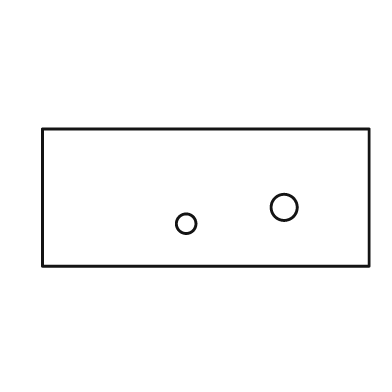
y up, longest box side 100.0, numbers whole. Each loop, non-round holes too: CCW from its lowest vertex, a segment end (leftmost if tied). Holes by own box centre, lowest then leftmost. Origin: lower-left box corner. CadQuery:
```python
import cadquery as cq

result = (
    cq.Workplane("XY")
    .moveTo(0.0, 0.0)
    .lineTo(100.0, 0.0)
    .lineTo(100.0, 42.0)
    .lineTo(0.0, 42.0)
    .close()
    .moveTo(44.0, 13.0)
    .circle(3.0)
    .moveTo(74.0, 18.0)
    .circle(4.0)
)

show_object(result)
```